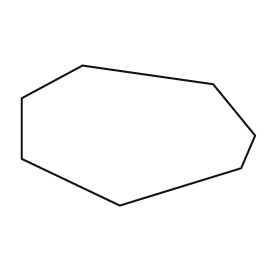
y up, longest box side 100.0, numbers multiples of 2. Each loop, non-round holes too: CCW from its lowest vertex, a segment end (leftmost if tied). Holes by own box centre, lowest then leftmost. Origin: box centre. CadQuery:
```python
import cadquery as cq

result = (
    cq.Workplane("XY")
    .moveTo(-8.0, -30.0)
    .lineTo(44.0, -14.0)
    .lineTo(50.0, 0.0)
    .lineTo(32.0, 22.0)
    .lineTo(-24.0, 30.0)
    .lineTo(-50.0, 16.0)
    .lineTo(-50.0, -10.0)
    .close()
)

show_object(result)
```